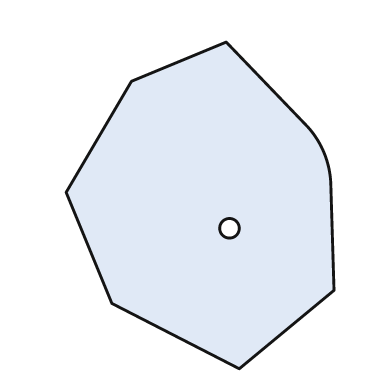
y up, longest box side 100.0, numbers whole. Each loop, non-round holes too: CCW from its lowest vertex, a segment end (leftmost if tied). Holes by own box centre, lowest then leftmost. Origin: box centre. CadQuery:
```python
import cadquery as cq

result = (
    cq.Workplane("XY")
    .moveTo(12.0, -50.0)
    .lineTo(41.0, -26.0)
    .lineTo(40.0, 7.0)
    .threePointArc((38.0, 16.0), (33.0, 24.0))
    .lineTo(8.0, 50.0)
    .lineTo(-21.0, 38.0)
    .lineTo(-41.0, 4.0)
    .lineTo(-27.0, -30.0)
    .close()
    .moveTo(9.0, -7.0)
    .circle(3.0)
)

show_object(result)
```